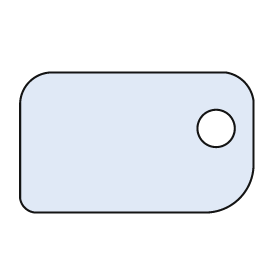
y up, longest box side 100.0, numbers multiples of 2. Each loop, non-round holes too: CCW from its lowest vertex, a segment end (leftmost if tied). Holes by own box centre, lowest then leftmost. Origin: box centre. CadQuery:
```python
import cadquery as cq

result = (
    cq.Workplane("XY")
    .moveTo(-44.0, -30.0)
    .lineTo(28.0, -30.0)
    .threePointArc((44.0, -24.0), (50.0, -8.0))
    .lineTo(50.0, 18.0)
    .threePointArc((46.0, 26.0), (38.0, 30.0))
    .lineTo(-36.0, 30.0)
    .threePointArc((-46.0, 26.0), (-50.0, 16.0))
    .lineTo(-50.0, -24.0)
    .threePointArc((-48.0, -28.0), (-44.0, -30.0))
    .close()
    .moveTo(34.0, 6.0)
    .circle(8.0)
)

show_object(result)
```